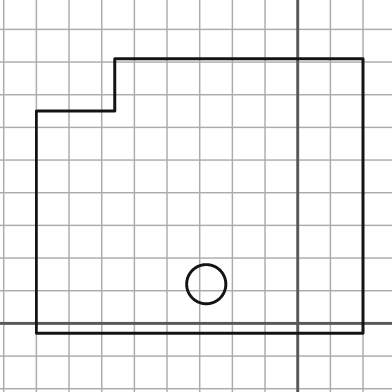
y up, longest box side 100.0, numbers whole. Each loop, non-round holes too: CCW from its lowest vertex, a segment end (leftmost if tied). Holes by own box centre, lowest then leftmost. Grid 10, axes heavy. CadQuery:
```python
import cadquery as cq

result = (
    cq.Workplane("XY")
    .moveTo(-80.0, -3.0)
    .lineTo(20.0, -3.0)
    .lineTo(20.0, 81.0)
    .lineTo(-56.0, 81.0)
    .lineTo(-56.0, 65.0)
    .lineTo(-80.0, 65.0)
    .close()
    .moveTo(-28.0, 12.0)
    .circle(6.0)
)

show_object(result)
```